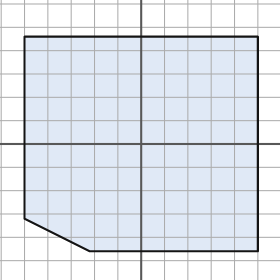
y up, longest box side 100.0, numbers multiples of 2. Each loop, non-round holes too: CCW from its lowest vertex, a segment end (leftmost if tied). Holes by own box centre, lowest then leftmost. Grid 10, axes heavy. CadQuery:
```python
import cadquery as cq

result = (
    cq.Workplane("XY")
    .moveTo(-22.0, -46.0)
    .lineTo(50.0, -46.0)
    .lineTo(50.0, 46.0)
    .lineTo(-50.0, 46.0)
    .lineTo(-50.0, -32.0)
    .close()
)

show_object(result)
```